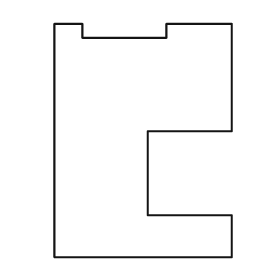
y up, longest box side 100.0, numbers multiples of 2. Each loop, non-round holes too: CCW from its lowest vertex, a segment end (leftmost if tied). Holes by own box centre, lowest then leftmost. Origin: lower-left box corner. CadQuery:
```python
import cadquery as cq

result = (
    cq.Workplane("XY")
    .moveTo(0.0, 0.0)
    .lineTo(76.0, 0.0)
    .lineTo(76.0, 18.0)
    .lineTo(40.0, 18.0)
    .lineTo(40.0, 54.0)
    .lineTo(76.0, 54.0)
    .lineTo(76.0, 100.0)
    .lineTo(48.0, 100.0)
    .lineTo(48.0, 94.0)
    .lineTo(12.0, 94.0)
    .lineTo(12.0, 100.0)
    .lineTo(0.0, 100.0)
    .close()
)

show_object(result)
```